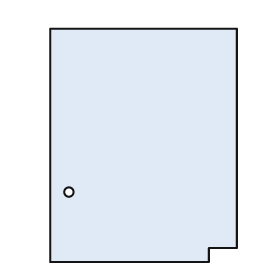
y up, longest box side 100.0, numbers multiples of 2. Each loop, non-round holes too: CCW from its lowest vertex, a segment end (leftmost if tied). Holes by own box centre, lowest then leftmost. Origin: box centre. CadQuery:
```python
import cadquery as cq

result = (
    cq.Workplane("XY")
    .moveTo(-40.0, -50.0)
    .lineTo(28.0, -50.0)
    .lineTo(28.0, -44.0)
    .lineTo(40.0, -44.0)
    .lineTo(40.0, 50.0)
    .lineTo(-40.0, 50.0)
    .close()
    .moveTo(-32.0, -20.0)
    .circle(2.0)
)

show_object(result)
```